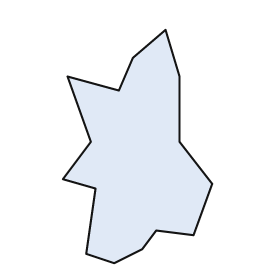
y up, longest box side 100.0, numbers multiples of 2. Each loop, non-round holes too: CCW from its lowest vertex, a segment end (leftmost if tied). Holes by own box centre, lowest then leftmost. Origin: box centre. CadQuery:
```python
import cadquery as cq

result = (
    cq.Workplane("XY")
    .moveTo(-10.0, -50.0)
    .lineTo(2.0, -44.0)
    .lineTo(8.0, -36.0)
    .lineTo(24.0, -38.0)
    .lineTo(32.0, -16.0)
    .lineTo(18.0, 2.0)
    .lineTo(18.0, 30.0)
    .lineTo(12.0, 50.0)
    .lineTo(-2.0, 38.0)
    .lineTo(-8.0, 24.0)
    .lineTo(-30.0, 30.0)
    .lineTo(-20.0, 2.0)
    .lineTo(-32.0, -14.0)
    .lineTo(-18.0, -18.0)
    .lineTo(-22.0, -46.0)
    .close()
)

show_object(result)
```